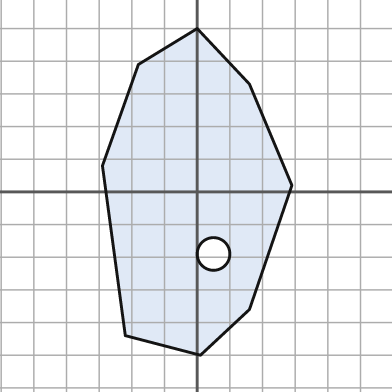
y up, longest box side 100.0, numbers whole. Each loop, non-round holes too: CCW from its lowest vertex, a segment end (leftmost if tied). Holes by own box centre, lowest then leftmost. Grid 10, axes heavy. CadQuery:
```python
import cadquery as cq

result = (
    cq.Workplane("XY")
    .moveTo(1.0, -50.0)
    .lineTo(16.0, -36.0)
    .lineTo(29.0, 2.0)
    .lineTo(16.0, 33.0)
    .lineTo(0.0, 50.0)
    .lineTo(-18.0, 39.0)
    .lineTo(-29.0, 8.0)
    .lineTo(-22.0, -44.0)
    .close()
    .moveTo(5.0, -19.0)
    .circle(5.0)
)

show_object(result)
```